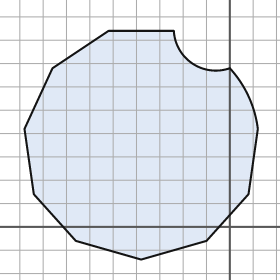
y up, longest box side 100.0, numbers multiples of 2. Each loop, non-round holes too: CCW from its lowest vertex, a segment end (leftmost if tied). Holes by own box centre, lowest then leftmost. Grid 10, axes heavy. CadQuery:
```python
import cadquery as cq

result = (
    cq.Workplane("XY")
    .moveTo(-38.0, -14.0)
    .lineTo(-10.0, -6.0)
    .lineTo(8.0, 14.0)
    .lineTo(12.0, 42.0)
    .threePointArc((8.0, 56.0), (0.0, 68.0))
    .threePointArc((-16.0, 70.0), (-24.0, 84.0))
    .lineTo(-52.0, 84.0)
    .lineTo(-76.0, 68.0)
    .lineTo(-88.0, 42.0)
    .lineTo(-84.0, 14.0)
    .lineTo(-66.0, -6.0)
    .close()
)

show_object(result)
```